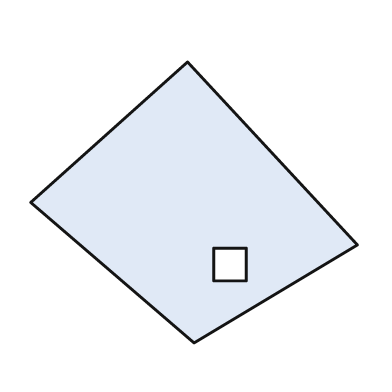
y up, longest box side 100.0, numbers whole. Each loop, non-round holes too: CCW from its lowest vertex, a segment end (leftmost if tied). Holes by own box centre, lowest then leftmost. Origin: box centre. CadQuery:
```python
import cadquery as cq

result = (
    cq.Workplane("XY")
    .moveTo(0.0, -43.0)
    .lineTo(50.0, -13.0)
    .lineTo(-2.0, 43.0)
    .lineTo(-50.0, 0.0)
    .close()
    .moveTo(6.0, -24.0)
    .lineTo(16.0, -24.0)
    .lineTo(16.0, -14.0)
    .lineTo(6.0, -14.0)
    .close()
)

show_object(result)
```